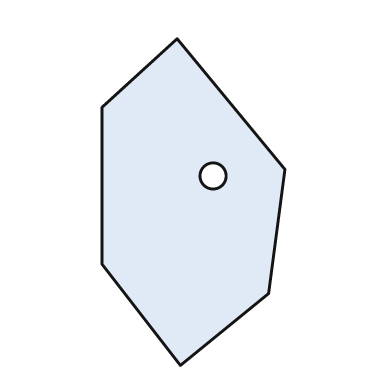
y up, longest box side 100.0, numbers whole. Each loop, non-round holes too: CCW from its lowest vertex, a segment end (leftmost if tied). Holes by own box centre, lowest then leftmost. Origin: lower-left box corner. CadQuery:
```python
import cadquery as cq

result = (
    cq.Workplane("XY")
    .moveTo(24.0, 0.0)
    .lineTo(51.0, 22.0)
    .lineTo(56.0, 60.0)
    .lineTo(23.0, 100.0)
    .lineTo(0.0, 79.0)
    .lineTo(0.0, 31.0)
    .close()
    .moveTo(34.0, 58.0)
    .circle(4.0)
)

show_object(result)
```